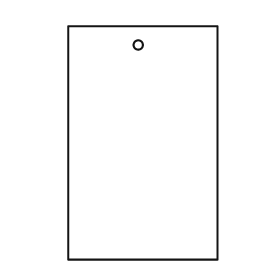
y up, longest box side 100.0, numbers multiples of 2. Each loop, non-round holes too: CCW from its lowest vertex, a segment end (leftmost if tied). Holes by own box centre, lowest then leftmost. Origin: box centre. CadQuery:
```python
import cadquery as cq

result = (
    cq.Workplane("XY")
    .moveTo(-32.0, -50.0)
    .lineTo(32.0, -50.0)
    .lineTo(32.0, 50.0)
    .lineTo(-32.0, 50.0)
    .close()
    .moveTo(-2.0, 42.0)
    .circle(2.0)
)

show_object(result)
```